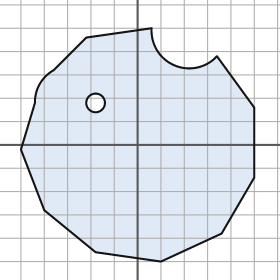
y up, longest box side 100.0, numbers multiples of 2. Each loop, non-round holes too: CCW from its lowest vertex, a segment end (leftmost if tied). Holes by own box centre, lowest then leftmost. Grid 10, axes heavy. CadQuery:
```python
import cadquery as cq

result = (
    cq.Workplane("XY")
    .moveTo(10.0, -50.0)
    .lineTo(36.0, -38.0)
    .lineTo(50.0, -14.0)
    .lineTo(50.0, 16.0)
    .lineTo(34.0, 38.0)
    .threePointArc((16.0, 34.0), (6.0, 50.0))
    .lineTo(-22.0, 46.0)
    .lineTo(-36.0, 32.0)
    .threePointArc((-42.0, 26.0), (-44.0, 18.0))
    .lineTo(-50.0, -2.0)
    .lineTo(-40.0, -28.0)
    .lineTo(-18.0, -46.0)
    .close()
    .moveTo(-18.0, 18.0)
    .circle(4.0)
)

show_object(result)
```